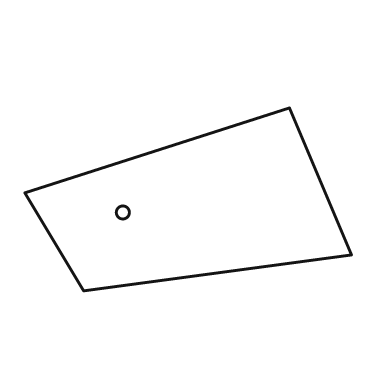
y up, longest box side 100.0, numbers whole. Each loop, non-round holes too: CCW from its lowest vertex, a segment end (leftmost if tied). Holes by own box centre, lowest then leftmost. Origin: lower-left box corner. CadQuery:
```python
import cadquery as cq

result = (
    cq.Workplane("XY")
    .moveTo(18.0, 0.0)
    .lineTo(100.0, 11.0)
    .lineTo(81.0, 56.0)
    .lineTo(0.0, 30.0)
    .close()
    .moveTo(30.0, 24.0)
    .circle(2.0)
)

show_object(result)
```